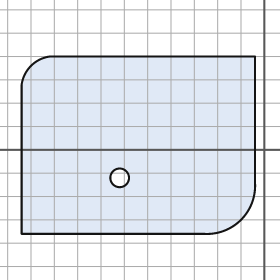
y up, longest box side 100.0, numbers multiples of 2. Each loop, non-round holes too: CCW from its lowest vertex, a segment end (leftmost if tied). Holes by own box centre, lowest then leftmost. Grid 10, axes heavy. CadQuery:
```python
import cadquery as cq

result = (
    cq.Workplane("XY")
    .moveTo(-104.0, -36.0)
    .lineTo(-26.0, -36.0)
    .threePointArc((-10.0, -30.0), (-4.0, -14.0))
    .lineTo(-4.0, 40.0)
    .lineTo(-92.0, 40.0)
    .threePointArc((-100.0, 36.0), (-104.0, 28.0))
    .close()
    .moveTo(-62.0, -12.0)
    .circle(4.0)
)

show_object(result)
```